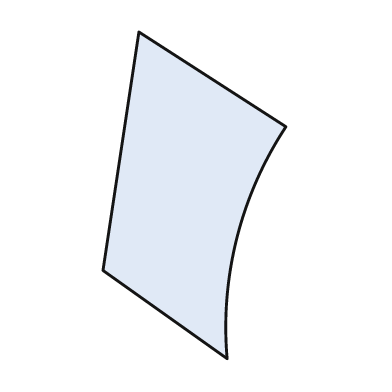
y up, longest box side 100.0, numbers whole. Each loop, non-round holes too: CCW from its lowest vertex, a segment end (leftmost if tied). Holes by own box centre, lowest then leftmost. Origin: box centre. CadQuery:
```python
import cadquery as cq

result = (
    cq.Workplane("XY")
    .moveTo(10.0, -50.0)
    .threePointArc((13.0, -13.0), (28.0, 21.0))
    .lineTo(-17.0, 50.0)
    .lineTo(-28.0, -23.0)
    .close()
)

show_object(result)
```